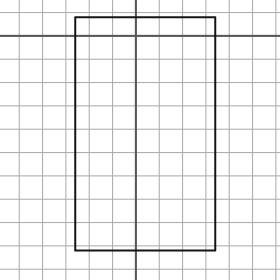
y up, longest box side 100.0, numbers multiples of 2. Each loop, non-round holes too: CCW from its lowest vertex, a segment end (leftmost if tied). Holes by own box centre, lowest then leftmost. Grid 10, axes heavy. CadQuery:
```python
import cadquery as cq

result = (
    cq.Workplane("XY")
    .moveTo(-26.0, -92.0)
    .lineTo(34.0, -92.0)
    .lineTo(34.0, 8.0)
    .lineTo(-26.0, 8.0)
    .close()
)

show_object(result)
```